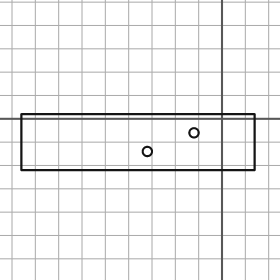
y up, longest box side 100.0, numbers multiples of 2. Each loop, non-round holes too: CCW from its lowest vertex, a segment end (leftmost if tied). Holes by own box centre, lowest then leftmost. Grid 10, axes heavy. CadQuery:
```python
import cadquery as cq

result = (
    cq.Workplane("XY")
    .moveTo(-86.0, -22.0)
    .lineTo(14.0, -22.0)
    .lineTo(14.0, 2.0)
    .lineTo(-86.0, 2.0)
    .close()
    .moveTo(-32.0, -14.0)
    .circle(2.0)
    .moveTo(-12.0, -6.0)
    .circle(2.0)
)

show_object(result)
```